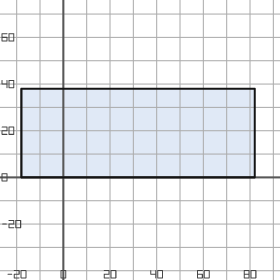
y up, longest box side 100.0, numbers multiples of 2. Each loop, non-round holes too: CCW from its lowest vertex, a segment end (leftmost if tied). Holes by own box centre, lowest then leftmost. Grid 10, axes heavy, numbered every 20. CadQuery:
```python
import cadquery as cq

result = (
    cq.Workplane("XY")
    .moveTo(-18.0, 0.0)
    .lineTo(82.0, 0.0)
    .lineTo(82.0, 38.0)
    .lineTo(-18.0, 38.0)
    .close()
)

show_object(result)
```